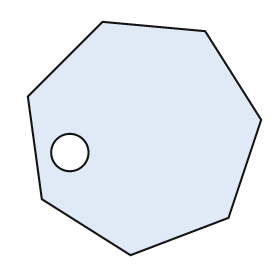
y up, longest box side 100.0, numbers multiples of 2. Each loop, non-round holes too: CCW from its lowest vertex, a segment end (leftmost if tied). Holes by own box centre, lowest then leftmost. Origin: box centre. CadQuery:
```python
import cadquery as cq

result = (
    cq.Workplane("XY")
    .moveTo(-6.0, -50.0)
    .lineTo(36.0, -34.0)
    .lineTo(50.0, 8.0)
    .lineTo(26.0, 46.0)
    .lineTo(-18.0, 50.0)
    .lineTo(-50.0, 18.0)
    .lineTo(-44.0, -26.0)
    .close()
    .moveTo(-32.0, -6.0)
    .circle(8.0)
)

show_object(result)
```